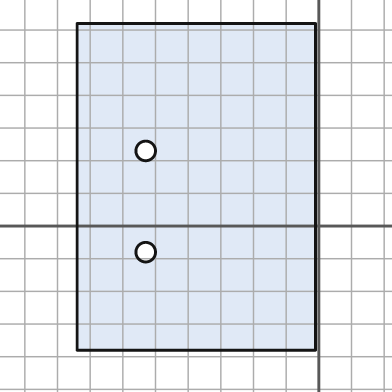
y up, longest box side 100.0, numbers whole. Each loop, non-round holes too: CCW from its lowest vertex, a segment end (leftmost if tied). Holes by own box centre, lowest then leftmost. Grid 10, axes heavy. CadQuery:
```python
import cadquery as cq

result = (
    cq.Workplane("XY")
    .moveTo(-74.0, -38.0)
    .lineTo(-1.0, -38.0)
    .lineTo(-1.0, 62.0)
    .lineTo(-74.0, 62.0)
    .close()
    .moveTo(-53.0, -8.0)
    .circle(3.0)
    .moveTo(-53.0, 23.0)
    .circle(3.0)
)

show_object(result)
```